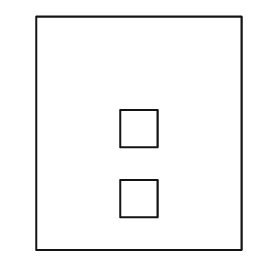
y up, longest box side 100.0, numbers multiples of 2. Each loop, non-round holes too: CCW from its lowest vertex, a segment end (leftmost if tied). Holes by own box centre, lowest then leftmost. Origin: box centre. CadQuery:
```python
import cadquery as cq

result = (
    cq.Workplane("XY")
    .moveTo(-44.0, -50.0)
    .lineTo(44.0, -50.0)
    .lineTo(44.0, 50.0)
    .lineTo(-44.0, 50.0)
    .close()
    .moveTo(-8.0, -36.0)
    .lineTo(8.0, -36.0)
    .lineTo(8.0, -20.0)
    .lineTo(-8.0, -20.0)
    .close()
    .moveTo(-8.0, -6.0)
    .lineTo(8.0, -6.0)
    .lineTo(8.0, 10.0)
    .lineTo(-8.0, 10.0)
    .close()
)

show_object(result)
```